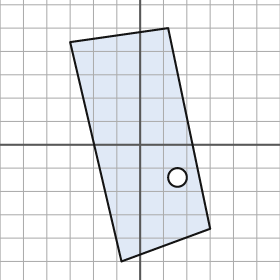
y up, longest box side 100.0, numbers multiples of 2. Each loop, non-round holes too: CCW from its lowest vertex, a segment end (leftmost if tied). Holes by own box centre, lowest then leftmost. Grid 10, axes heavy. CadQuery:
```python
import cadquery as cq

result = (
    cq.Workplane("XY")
    .moveTo(-8.0, -50.0)
    .lineTo(30.0, -36.0)
    .lineTo(12.0, 50.0)
    .lineTo(-30.0, 44.0)
    .close()
    .moveTo(16.0, -14.0)
    .circle(4.0)
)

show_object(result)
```